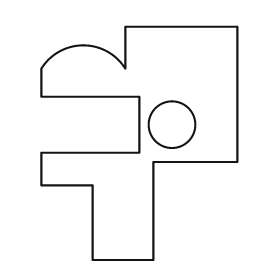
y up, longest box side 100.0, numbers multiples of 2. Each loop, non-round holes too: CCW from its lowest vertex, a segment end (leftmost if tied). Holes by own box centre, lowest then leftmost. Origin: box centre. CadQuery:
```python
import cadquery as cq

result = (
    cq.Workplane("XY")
    .moveTo(-20.0, -50.0)
    .lineTo(6.0, -50.0)
    .lineTo(6.0, -8.0)
    .lineTo(42.0, -8.0)
    .lineTo(42.0, 50.0)
    .lineTo(-6.0, 50.0)
    .lineTo(-6.0, 32.0)
    .threePointArc((-24.0, 42.0), (-42.0, 32.0))
    .lineTo(-42.0, 20.0)
    .lineTo(0.0, 20.0)
    .lineTo(0.0, -4.0)
    .lineTo(-42.0, -4.0)
    .lineTo(-42.0, -18.0)
    .lineTo(-20.0, -18.0)
    .close()
    .moveTo(14.0, 8.0)
    .circle(10.0)
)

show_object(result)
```